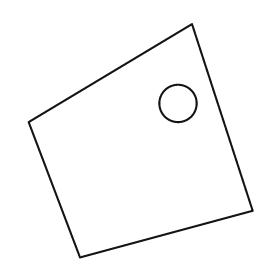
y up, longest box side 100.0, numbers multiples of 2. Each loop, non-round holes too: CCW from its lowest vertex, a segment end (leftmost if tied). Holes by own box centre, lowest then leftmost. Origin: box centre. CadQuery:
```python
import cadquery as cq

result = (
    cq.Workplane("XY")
    .moveTo(-26.0, -50.0)
    .lineTo(48.0, -30.0)
    .lineTo(22.0, 50.0)
    .lineTo(-48.0, 8.0)
    .close()
    .moveTo(16.0, 16.0)
    .circle(8.0)
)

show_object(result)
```